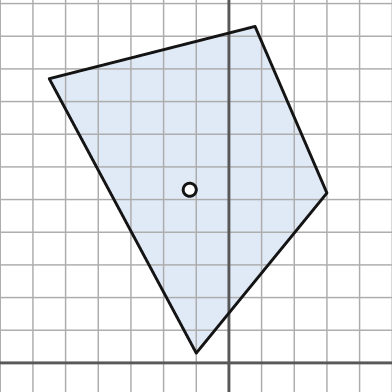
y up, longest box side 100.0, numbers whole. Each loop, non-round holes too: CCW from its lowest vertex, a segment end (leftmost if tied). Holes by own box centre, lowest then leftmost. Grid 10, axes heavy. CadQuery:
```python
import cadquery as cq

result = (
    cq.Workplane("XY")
    .moveTo(-10.0, 3.0)
    .lineTo(30.0, 52.0)
    .lineTo(8.0, 103.0)
    .lineTo(-55.0, 87.0)
    .close()
    .moveTo(-12.0, 53.0)
    .circle(2.0)
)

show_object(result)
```